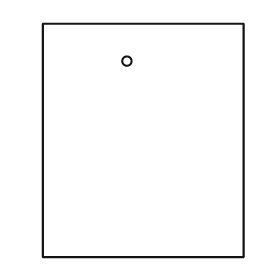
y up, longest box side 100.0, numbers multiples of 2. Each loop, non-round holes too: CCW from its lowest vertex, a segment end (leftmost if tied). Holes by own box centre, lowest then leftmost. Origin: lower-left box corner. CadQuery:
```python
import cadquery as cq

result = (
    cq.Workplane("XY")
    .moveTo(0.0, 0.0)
    .lineTo(86.0, 0.0)
    .lineTo(86.0, 100.0)
    .lineTo(0.0, 100.0)
    .close()
    .moveTo(36.0, 84.0)
    .circle(2.0)
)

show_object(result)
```